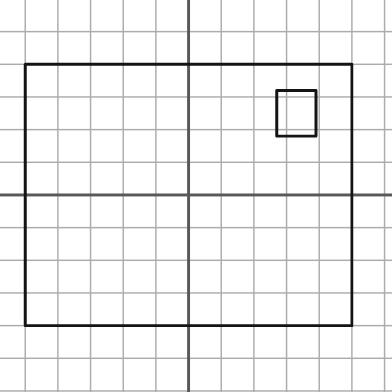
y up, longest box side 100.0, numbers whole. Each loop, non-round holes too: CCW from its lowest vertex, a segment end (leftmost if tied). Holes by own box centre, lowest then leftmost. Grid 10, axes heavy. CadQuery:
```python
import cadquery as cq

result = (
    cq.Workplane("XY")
    .moveTo(-50.0, -40.0)
    .lineTo(50.0, -40.0)
    .lineTo(50.0, 40.0)
    .lineTo(-50.0, 40.0)
    .close()
    .moveTo(27.0, 18.0)
    .lineTo(39.0, 18.0)
    .lineTo(39.0, 32.0)
    .lineTo(27.0, 32.0)
    .close()
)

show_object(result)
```